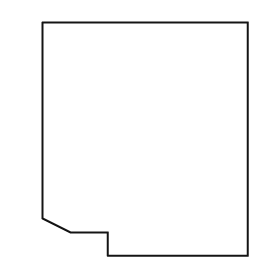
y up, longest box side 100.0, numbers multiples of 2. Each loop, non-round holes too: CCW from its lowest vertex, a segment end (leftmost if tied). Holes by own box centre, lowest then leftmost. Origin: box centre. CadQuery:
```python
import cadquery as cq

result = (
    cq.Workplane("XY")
    .moveTo(-16.0, -50.0)
    .lineTo(44.0, -50.0)
    .lineTo(44.0, 50.0)
    .lineTo(-44.0, 50.0)
    .lineTo(-44.0, -34.0)
    .lineTo(-32.0, -40.0)
    .lineTo(-16.0, -40.0)
    .close()
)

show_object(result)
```